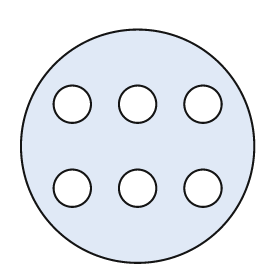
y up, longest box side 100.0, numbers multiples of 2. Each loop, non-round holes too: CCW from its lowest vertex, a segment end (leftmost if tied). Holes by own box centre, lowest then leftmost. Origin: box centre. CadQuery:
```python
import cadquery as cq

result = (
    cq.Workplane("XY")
    .moveTo(0.0, 0.0)
    .circle(50.0)
    .moveTo(-28.0, -18.0)
    .circle(8.0)
    .moveTo(0.0, -18.0)
    .circle(8.0)
    .moveTo(28.0, -18.0)
    .circle(8.0)
    .moveTo(-28.0, 18.0)
    .circle(8.0)
    .moveTo(0.0, 18.0)
    .circle(8.0)
    .moveTo(28.0, 18.0)
    .circle(8.0)
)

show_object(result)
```